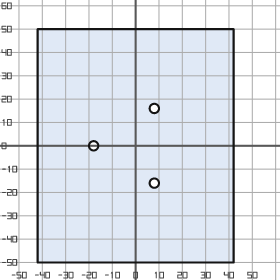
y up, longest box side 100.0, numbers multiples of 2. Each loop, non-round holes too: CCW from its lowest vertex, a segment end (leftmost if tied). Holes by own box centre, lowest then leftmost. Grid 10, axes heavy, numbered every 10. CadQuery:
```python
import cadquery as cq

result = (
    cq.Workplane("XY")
    .moveTo(-42.0, -50.0)
    .lineTo(42.0, -50.0)
    .lineTo(42.0, 50.0)
    .lineTo(-42.0, 50.0)
    .close()
    .moveTo(8.0, -16.0)
    .circle(2.0)
    .moveTo(-18.0, 0.0)
    .circle(2.0)
    .moveTo(8.0, 16.0)
    .circle(2.0)
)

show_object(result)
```